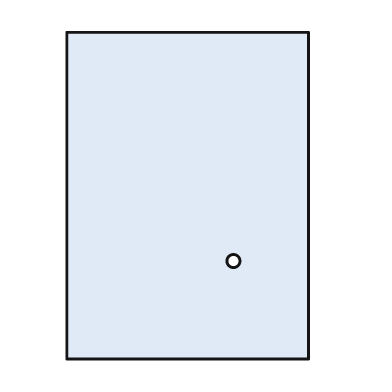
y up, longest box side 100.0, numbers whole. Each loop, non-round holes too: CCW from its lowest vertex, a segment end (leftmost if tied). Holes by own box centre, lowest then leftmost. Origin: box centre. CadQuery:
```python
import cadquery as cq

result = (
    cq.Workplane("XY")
    .moveTo(-37.0, -50.0)
    .lineTo(37.0, -50.0)
    .lineTo(37.0, 50.0)
    .lineTo(-37.0, 50.0)
    .close()
    .moveTo(14.0, -20.0)
    .circle(2.0)
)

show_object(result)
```